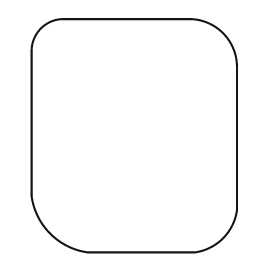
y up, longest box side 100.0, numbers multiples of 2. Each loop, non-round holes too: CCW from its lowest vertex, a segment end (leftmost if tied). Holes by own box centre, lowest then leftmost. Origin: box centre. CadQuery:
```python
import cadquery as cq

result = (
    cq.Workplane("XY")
    .moveTo(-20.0, -50.0)
    .lineTo(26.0, -50.0)
    .threePointArc((38.0, -44.0), (44.0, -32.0))
    .lineTo(44.0, 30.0)
    .threePointArc((38.0, 44.0), (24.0, 50.0))
    .lineTo(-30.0, 50.0)
    .threePointArc((-40.0, 46.0), (-44.0, 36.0))
    .lineTo(-44.0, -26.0)
    .threePointArc((-36.0, -42.0), (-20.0, -50.0))
    .close()
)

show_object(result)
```